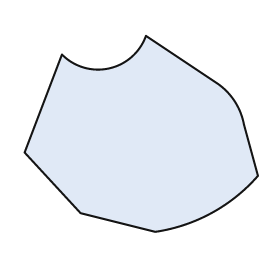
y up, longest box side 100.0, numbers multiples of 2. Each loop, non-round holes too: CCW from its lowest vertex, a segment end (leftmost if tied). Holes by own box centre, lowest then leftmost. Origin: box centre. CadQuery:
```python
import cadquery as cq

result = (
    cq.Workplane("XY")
    .moveTo(6.0, -42.0)
    .threePointArc((30.0, -34.0), (50.0, -18.0))
    .lineTo(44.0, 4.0)
    .threePointArc((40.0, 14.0), (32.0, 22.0))
    .lineTo(2.0, 42.0)
    .threePointArc((-14.0, 28.0), (-34.0, 34.0))
    .lineTo(-50.0, -8.0)
    .lineTo(-26.0, -34.0)
    .close()
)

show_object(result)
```